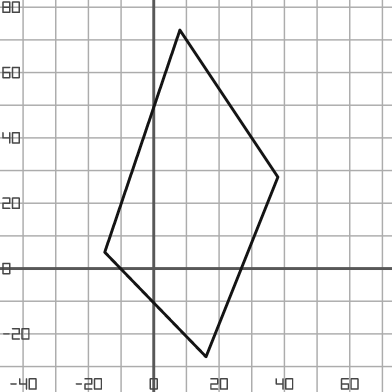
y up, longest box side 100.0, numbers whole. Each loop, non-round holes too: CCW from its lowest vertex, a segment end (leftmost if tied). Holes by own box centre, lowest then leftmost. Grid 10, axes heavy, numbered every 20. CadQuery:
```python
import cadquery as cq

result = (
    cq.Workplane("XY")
    .moveTo(16.0, -27.0)
    .lineTo(38.0, 28.0)
    .lineTo(8.0, 73.0)
    .lineTo(-15.0, 5.0)
    .close()
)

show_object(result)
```